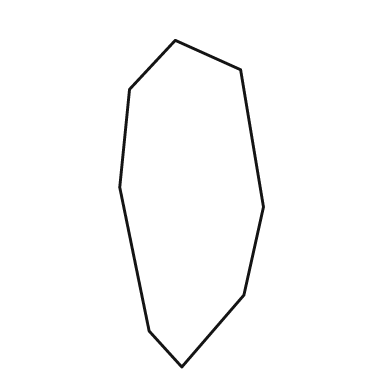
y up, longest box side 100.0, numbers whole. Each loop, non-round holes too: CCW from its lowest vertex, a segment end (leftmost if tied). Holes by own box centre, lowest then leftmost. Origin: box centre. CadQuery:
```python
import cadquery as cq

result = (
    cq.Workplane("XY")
    .moveTo(-3.0, -50.0)
    .lineTo(16.0, -28.0)
    .lineTo(22.0, -1.0)
    .lineTo(15.0, 41.0)
    .lineTo(-5.0, 50.0)
    .lineTo(-19.0, 35.0)
    .lineTo(-22.0, 5.0)
    .lineTo(-13.0, -39.0)
    .close()
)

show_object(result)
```